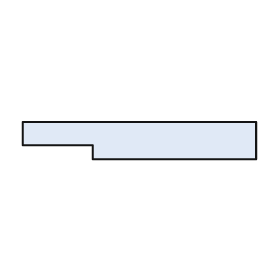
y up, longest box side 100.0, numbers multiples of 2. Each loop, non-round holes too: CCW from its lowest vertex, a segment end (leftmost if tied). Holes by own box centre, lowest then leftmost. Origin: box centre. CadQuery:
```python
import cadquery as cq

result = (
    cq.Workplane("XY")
    .moveTo(-20.0, -8.0)
    .lineTo(50.0, -8.0)
    .lineTo(50.0, 8.0)
    .lineTo(-50.0, 8.0)
    .lineTo(-50.0, -2.0)
    .lineTo(-20.0, -2.0)
    .close()
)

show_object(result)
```